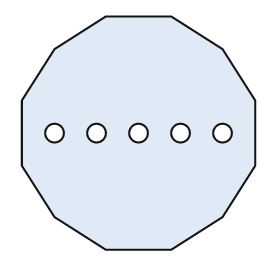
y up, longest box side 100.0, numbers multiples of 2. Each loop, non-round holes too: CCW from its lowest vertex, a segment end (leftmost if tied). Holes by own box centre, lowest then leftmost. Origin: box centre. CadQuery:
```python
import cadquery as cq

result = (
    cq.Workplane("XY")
    .moveTo(-14.0, -50.0)
    .lineTo(14.0, -50.0)
    .lineTo(36.0, -36.0)
    .lineTo(50.0, -14.0)
    .lineTo(50.0, 14.0)
    .lineTo(36.0, 36.0)
    .lineTo(14.0, 50.0)
    .lineTo(-14.0, 50.0)
    .lineTo(-36.0, 36.0)
    .lineTo(-50.0, 14.0)
    .lineTo(-50.0, -14.0)
    .lineTo(-36.0, -36.0)
    .close()
    .moveTo(-36.0, 0.0)
    .circle(4.0)
    .moveTo(-18.0, 0.0)
    .circle(4.0)
    .moveTo(0.0, 0.0)
    .circle(4.0)
    .moveTo(18.0, 0.0)
    .circle(4.0)
    .moveTo(36.0, 0.0)
    .circle(4.0)
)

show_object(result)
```